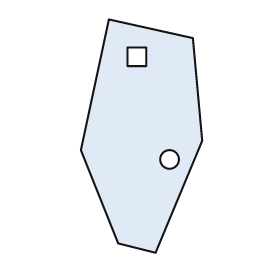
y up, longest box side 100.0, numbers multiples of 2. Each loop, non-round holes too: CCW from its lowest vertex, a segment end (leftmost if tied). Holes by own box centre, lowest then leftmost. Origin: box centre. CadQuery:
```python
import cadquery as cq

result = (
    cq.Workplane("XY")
    .moveTo(6.0, -50.0)
    .lineTo(26.0, -2.0)
    .lineTo(22.0, 42.0)
    .lineTo(-14.0, 50.0)
    .lineTo(-26.0, -6.0)
    .lineTo(-10.0, -46.0)
    .close()
    .moveTo(12.0, -10.0)
    .circle(4.0)
    .moveTo(-6.0, 30.0)
    .lineTo(2.0, 30.0)
    .lineTo(2.0, 38.0)
    .lineTo(-6.0, 38.0)
    .close()
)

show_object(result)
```